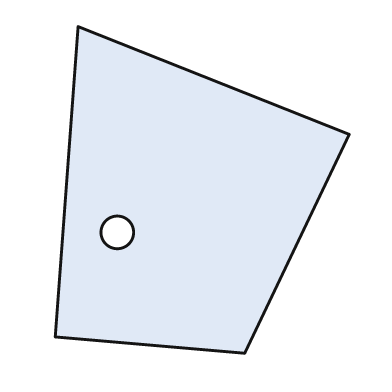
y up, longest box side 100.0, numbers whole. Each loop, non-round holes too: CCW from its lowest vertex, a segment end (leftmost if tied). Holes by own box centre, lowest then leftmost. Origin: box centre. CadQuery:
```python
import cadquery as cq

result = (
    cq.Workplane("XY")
    .moveTo(13.0, -50.0)
    .lineTo(45.0, 17.0)
    .lineTo(-38.0, 50.0)
    .lineTo(-45.0, -45.0)
    .close()
    .moveTo(-26.0, -13.0)
    .circle(5.0)
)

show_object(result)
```